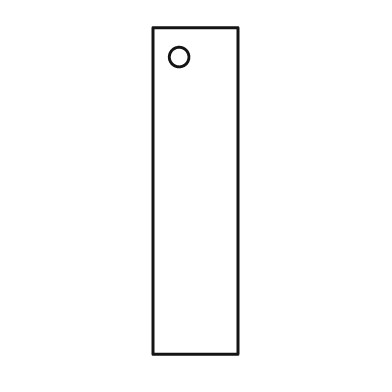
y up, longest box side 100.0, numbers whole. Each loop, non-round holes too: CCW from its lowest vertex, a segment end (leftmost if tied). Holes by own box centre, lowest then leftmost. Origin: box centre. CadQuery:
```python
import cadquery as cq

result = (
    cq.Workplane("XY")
    .moveTo(-13.0, -50.0)
    .lineTo(13.0, -50.0)
    .lineTo(13.0, 50.0)
    .lineTo(-13.0, 50.0)
    .close()
    .moveTo(-5.0, 41.0)
    .circle(3.0)
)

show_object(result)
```